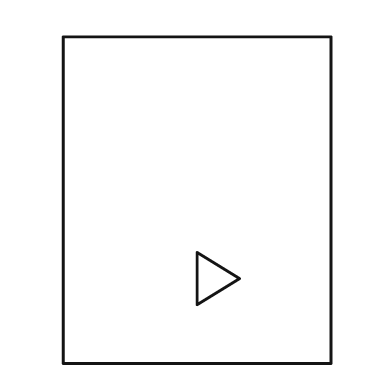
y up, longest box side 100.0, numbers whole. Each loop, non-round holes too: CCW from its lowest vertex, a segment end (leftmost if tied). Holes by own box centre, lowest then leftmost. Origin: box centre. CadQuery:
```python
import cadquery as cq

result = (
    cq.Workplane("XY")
    .moveTo(-41.0, -50.0)
    .lineTo(41.0, -50.0)
    .lineTo(41.0, 50.0)
    .lineTo(-41.0, 50.0)
    .close()
    .moveTo(0.0, -32.0)
    .lineTo(13.0, -24.0)
    .lineTo(0.0, -16.0)
    .close()
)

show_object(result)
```